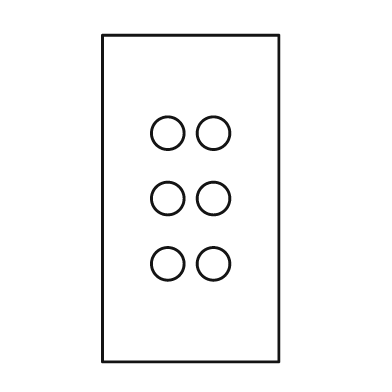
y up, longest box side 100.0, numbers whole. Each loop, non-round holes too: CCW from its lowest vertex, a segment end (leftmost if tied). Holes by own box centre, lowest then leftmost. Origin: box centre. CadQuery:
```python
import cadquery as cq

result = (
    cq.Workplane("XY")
    .moveTo(-27.0, -50.0)
    .lineTo(27.0, -50.0)
    .lineTo(27.0, 50.0)
    .lineTo(-27.0, 50.0)
    .close()
    .moveTo(-7.0, -20.0)
    .circle(5.0)
    .moveTo(7.0, -20.0)
    .circle(5.0)
    .moveTo(-7.0, 0.0)
    .circle(5.0)
    .moveTo(7.0, 0.0)
    .circle(5.0)
    .moveTo(-7.0, 20.0)
    .circle(5.0)
    .moveTo(7.0, 20.0)
    .circle(5.0)
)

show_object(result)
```